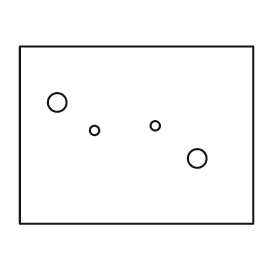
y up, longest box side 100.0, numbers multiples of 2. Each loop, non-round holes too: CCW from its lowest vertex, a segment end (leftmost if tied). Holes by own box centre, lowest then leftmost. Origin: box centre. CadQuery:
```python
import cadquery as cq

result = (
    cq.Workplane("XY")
    .moveTo(-50.0, -38.0)
    .lineTo(50.0, -38.0)
    .lineTo(50.0, 38.0)
    .lineTo(-50.0, 38.0)
    .close()
    .moveTo(26.0, -10.0)
    .circle(4.0)
    .moveTo(-18.0, 2.0)
    .circle(2.0)
    .moveTo(8.0, 4.0)
    .circle(2.0)
    .moveTo(-34.0, 14.0)
    .circle(4.0)
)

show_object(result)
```